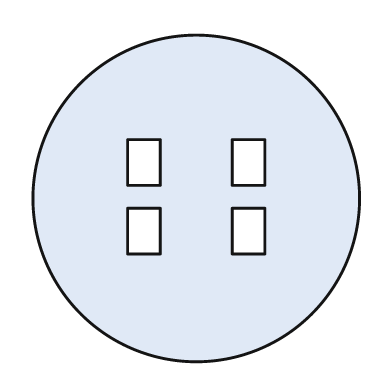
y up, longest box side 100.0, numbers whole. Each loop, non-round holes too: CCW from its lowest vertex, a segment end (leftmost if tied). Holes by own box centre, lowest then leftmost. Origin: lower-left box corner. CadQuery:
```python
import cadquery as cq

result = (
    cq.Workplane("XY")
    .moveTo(50.0, 50.0)
    .circle(50.0)
    .moveTo(29.0, 33.0)
    .lineTo(39.0, 33.0)
    .lineTo(39.0, 47.0)
    .lineTo(29.0, 47.0)
    .close()
    .moveTo(61.0, 33.0)
    .lineTo(71.0, 33.0)
    .lineTo(71.0, 47.0)
    .lineTo(61.0, 47.0)
    .close()
    .moveTo(29.0, 54.0)
    .lineTo(39.0, 54.0)
    .lineTo(39.0, 68.0)
    .lineTo(29.0, 68.0)
    .close()
    .moveTo(61.0, 54.0)
    .lineTo(71.0, 54.0)
    .lineTo(71.0, 68.0)
    .lineTo(61.0, 68.0)
    .close()
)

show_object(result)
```